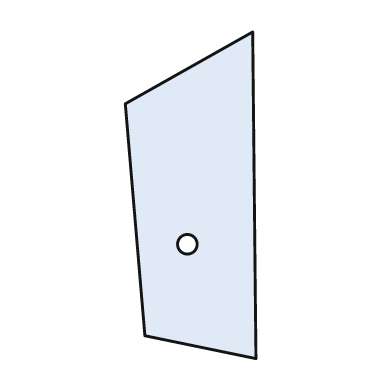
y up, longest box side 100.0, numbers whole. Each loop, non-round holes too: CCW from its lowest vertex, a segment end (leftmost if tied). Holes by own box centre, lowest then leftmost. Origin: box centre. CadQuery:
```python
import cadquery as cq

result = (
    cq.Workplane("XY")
    .moveTo(20.0, -50.0)
    .lineTo(19.0, 50.0)
    .lineTo(-20.0, 28.0)
    .lineTo(-14.0, -43.0)
    .close()
    .moveTo(-1.0, -15.0)
    .circle(3.0)
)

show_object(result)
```